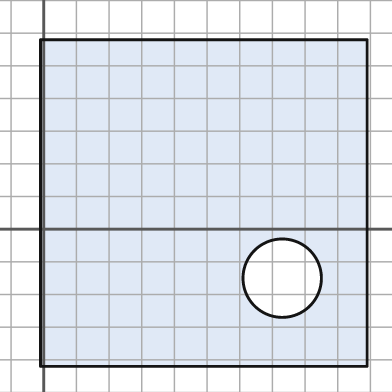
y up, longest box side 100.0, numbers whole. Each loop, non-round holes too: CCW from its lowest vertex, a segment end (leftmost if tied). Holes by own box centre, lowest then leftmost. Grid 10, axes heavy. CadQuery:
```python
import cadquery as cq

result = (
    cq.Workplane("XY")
    .moveTo(-1.0, -42.0)
    .lineTo(99.0, -42.0)
    .lineTo(99.0, 58.0)
    .lineTo(-1.0, 58.0)
    .close()
    .moveTo(73.0, -15.0)
    .circle(12.0)
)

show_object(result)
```